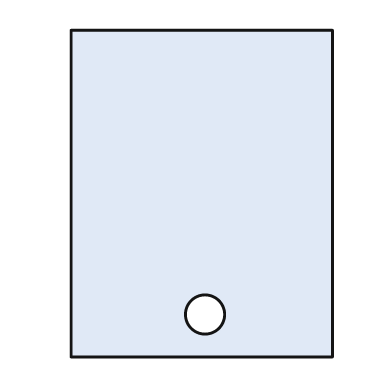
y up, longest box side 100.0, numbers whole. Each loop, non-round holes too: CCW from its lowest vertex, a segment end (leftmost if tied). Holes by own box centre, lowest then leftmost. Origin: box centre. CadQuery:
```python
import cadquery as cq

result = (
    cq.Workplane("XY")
    .moveTo(-40.0, -50.0)
    .lineTo(40.0, -50.0)
    .lineTo(40.0, 50.0)
    .lineTo(-40.0, 50.0)
    .close()
    .moveTo(1.0, -37.0)
    .circle(6.0)
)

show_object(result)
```